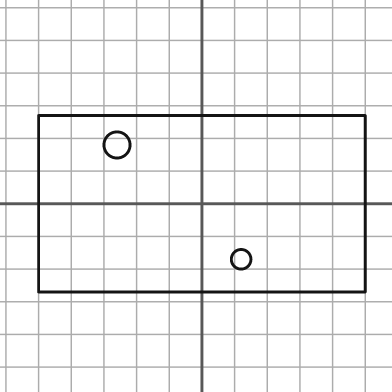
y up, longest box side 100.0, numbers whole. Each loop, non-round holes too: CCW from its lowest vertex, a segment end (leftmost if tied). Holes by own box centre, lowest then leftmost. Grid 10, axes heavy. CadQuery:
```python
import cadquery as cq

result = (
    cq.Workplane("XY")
    .moveTo(-50.0, -27.0)
    .lineTo(50.0, -27.0)
    .lineTo(50.0, 27.0)
    .lineTo(-50.0, 27.0)
    .close()
    .moveTo(12.0, -17.0)
    .circle(3.0)
    .moveTo(-26.0, 18.0)
    .circle(4.0)
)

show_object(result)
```